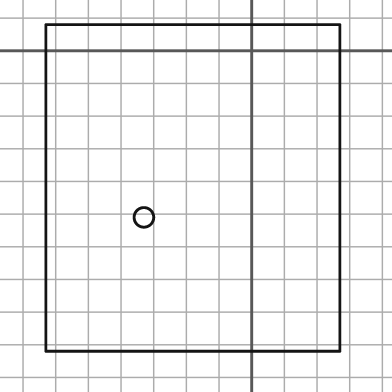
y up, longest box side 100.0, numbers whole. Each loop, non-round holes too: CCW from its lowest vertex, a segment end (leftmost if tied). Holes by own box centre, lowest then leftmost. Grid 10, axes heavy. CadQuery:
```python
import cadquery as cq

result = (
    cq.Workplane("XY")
    .moveTo(-63.0, -92.0)
    .lineTo(27.0, -92.0)
    .lineTo(27.0, 8.0)
    .lineTo(-63.0, 8.0)
    .close()
    .moveTo(-33.0, -51.0)
    .circle(3.0)
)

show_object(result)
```